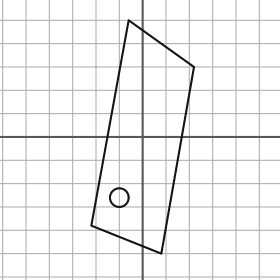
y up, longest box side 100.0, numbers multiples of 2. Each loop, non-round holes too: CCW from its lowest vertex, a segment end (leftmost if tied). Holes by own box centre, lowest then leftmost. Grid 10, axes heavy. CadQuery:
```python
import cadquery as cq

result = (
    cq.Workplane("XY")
    .moveTo(8.0, -50.0)
    .lineTo(22.0, 30.0)
    .lineTo(-6.0, 50.0)
    .lineTo(-22.0, -38.0)
    .close()
    .moveTo(-10.0, -26.0)
    .circle(4.0)
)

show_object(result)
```